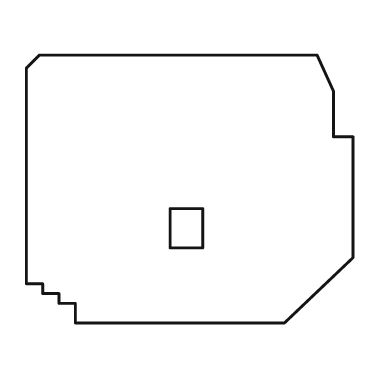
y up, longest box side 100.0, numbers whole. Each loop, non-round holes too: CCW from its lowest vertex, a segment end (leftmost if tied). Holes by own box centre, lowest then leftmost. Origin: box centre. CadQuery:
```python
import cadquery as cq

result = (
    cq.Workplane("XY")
    .moveTo(-35.0, -41.0)
    .lineTo(29.0, -41.0)
    .lineTo(50.0, -21.0)
    .lineTo(50.0, 16.0)
    .lineTo(44.0, 16.0)
    .lineTo(44.0, 30.0)
    .lineTo(39.0, 41.0)
    .lineTo(-46.0, 41.0)
    .lineTo(-50.0, 37.0)
    .lineTo(-50.0, -29.0)
    .lineTo(-45.0, -29.0)
    .lineTo(-45.0, -32.0)
    .lineTo(-40.0, -32.0)
    .lineTo(-40.0, -35.0)
    .lineTo(-35.0, -35.0)
    .close()
    .moveTo(-6.0, -18.0)
    .lineTo(4.0, -18.0)
    .lineTo(4.0, -6.0)
    .lineTo(-6.0, -6.0)
    .close()
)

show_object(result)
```